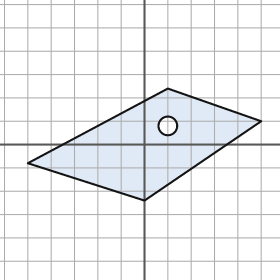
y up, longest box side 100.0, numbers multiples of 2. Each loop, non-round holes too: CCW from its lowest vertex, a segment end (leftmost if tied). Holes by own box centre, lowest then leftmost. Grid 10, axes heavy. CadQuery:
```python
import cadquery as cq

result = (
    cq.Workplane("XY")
    .moveTo(0.0, -24.0)
    .lineTo(50.0, 10.0)
    .lineTo(10.0, 24.0)
    .lineTo(-50.0, -8.0)
    .close()
    .moveTo(10.0, 8.0)
    .circle(4.0)
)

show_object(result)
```